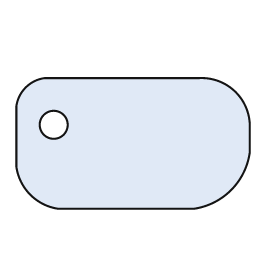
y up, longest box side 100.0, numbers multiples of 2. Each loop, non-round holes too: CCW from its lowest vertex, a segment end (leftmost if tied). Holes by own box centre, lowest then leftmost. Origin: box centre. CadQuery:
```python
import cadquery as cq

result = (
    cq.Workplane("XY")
    .moveTo(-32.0, -28.0)
    .lineTo(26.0, -28.0)
    .threePointArc((42.0, -20.0), (50.0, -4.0))
    .lineTo(50.0, 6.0)
    .threePointArc((44.0, 22.0), (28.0, 28.0))
    .lineTo(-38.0, 28.0)
    .threePointArc((-46.0, 24.0), (-50.0, 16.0))
    .lineTo(-50.0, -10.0)
    .threePointArc((-44.0, -22.0), (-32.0, -28.0))
    .close()
    .moveTo(-34.0, 8.0)
    .circle(6.0)
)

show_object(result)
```